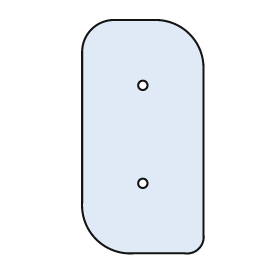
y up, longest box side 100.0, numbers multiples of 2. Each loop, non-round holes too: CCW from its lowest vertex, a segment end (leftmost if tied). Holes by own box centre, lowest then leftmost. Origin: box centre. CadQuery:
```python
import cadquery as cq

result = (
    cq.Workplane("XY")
    .moveTo(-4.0, -50.0)
    .lineTo(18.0, -50.0)
    .threePointArc((24.0, -48.0), (26.0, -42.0))
    .lineTo(26.0, 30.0)
    .threePointArc((20.0, 44.0), (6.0, 50.0))
    .lineTo(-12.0, 50.0)
    .threePointArc((-22.0, 46.0), (-26.0, 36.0))
    .lineTo(-26.0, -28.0)
    .threePointArc((-20.0, -44.0), (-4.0, -50.0))
    .close()
    .moveTo(0.0, -20.0)
    .circle(2.0)
    .moveTo(0.0, 22.0)
    .circle(2.0)
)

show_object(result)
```